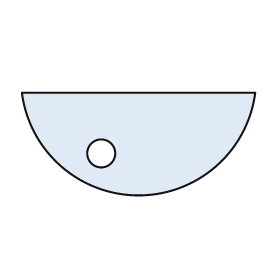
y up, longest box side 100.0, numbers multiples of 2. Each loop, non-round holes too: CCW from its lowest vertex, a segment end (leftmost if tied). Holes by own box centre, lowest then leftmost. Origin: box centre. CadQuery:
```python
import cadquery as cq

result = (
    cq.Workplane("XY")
    .moveTo(-50.0, 22.0)
    .threePointArc((0.0, -22.0), (50.0, 22.0))
    .close()
    .moveTo(-16.0, -4.0)
    .circle(6.0)
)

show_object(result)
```